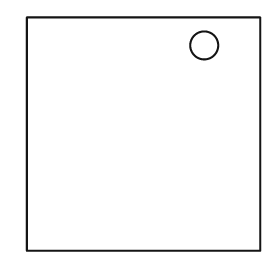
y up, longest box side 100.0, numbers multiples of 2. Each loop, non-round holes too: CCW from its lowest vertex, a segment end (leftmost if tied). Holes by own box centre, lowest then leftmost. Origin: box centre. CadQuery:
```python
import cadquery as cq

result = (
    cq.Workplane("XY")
    .moveTo(-50.0, -50.0)
    .lineTo(50.0, -50.0)
    .lineTo(50.0, 50.0)
    .lineTo(-50.0, 50.0)
    .close()
    .moveTo(26.0, 38.0)
    .circle(6.0)
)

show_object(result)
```